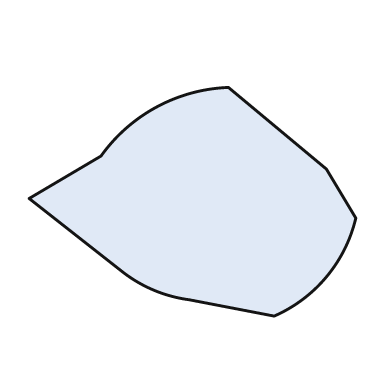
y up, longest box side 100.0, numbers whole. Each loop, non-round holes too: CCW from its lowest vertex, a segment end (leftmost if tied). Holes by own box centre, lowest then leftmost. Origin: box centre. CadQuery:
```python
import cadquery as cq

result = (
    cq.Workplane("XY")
    .moveTo(25.0, -35.0)
    .threePointArc((41.0, -23.0), (50.0, -5.0))
    .lineTo(41.0, 10.0)
    .lineTo(11.0, 35.0)
    .threePointArc((-11.0, 29.0), (-28.0, 14.0))
    .lineTo(-50.0, 1.0)
    .lineTo(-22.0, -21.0)
    .threePointArc((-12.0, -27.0), (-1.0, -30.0))
    .close()
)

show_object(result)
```